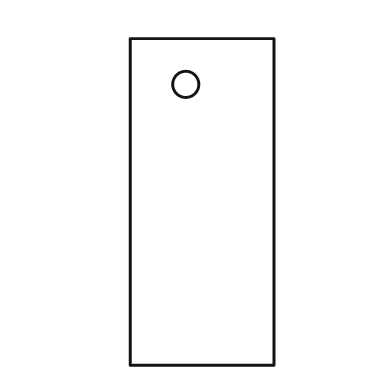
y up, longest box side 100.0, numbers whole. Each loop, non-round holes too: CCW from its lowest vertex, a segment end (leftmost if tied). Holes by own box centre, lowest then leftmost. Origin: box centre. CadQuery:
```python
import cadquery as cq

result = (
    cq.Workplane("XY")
    .moveTo(-22.0, -50.0)
    .lineTo(22.0, -50.0)
    .lineTo(22.0, 50.0)
    .lineTo(-22.0, 50.0)
    .close()
    .moveTo(-5.0, 36.0)
    .circle(4.0)
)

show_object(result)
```